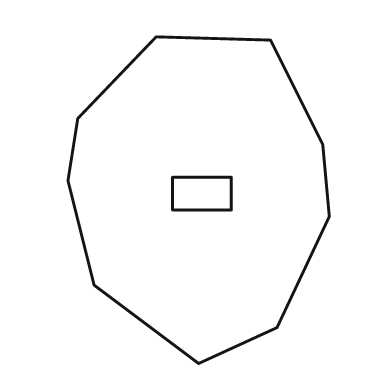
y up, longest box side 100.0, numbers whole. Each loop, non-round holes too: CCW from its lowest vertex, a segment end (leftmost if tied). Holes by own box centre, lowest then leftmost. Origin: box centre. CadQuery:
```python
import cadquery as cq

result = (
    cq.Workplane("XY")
    .moveTo(0.0, -50.0)
    .lineTo(24.0, -39.0)
    .lineTo(40.0, -5.0)
    .lineTo(38.0, 17.0)
    .lineTo(22.0, 49.0)
    .lineTo(-13.0, 50.0)
    .lineTo(-37.0, 25.0)
    .lineTo(-40.0, 6.0)
    .lineTo(-32.0, -26.0)
    .close()
    .moveTo(-8.0, -3.0)
    .lineTo(10.0, -3.0)
    .lineTo(10.0, 7.0)
    .lineTo(-8.0, 7.0)
    .close()
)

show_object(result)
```